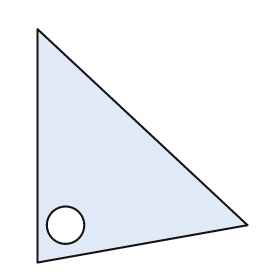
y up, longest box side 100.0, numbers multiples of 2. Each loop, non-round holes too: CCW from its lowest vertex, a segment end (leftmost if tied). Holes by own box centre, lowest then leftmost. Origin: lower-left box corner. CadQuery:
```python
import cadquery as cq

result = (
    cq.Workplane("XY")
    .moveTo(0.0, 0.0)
    .lineTo(90.0, 16.0)
    .lineTo(0.0, 100.0)
    .close()
    .moveTo(12.0, 16.0)
    .circle(8.0)
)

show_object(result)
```